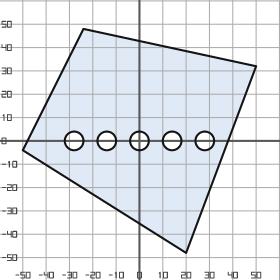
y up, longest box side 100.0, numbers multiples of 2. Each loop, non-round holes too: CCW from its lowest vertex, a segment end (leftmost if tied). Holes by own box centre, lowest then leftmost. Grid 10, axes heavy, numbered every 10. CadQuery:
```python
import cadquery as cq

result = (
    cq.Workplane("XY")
    .moveTo(20.0, -48.0)
    .lineTo(50.0, 32.0)
    .lineTo(-24.0, 48.0)
    .lineTo(-50.0, -4.0)
    .close()
    .moveTo(-28.0, 0.0)
    .circle(4.0)
    .moveTo(-14.0, 0.0)
    .circle(4.0)
    .moveTo(0.0, 0.0)
    .circle(4.0)
    .moveTo(14.0, 0.0)
    .circle(4.0)
    .moveTo(28.0, 0.0)
    .circle(4.0)
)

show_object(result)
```